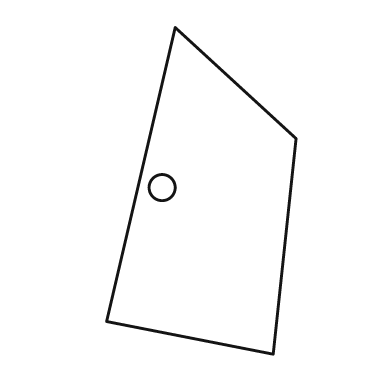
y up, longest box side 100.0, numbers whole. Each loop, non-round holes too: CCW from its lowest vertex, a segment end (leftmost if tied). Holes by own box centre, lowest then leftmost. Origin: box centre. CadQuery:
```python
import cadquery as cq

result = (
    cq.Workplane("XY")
    .moveTo(22.0, -50.0)
    .lineTo(29.0, 16.0)
    .lineTo(-8.0, 50.0)
    .lineTo(-29.0, -40.0)
    .close()
    .moveTo(-12.0, 1.0)
    .circle(4.0)
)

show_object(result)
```